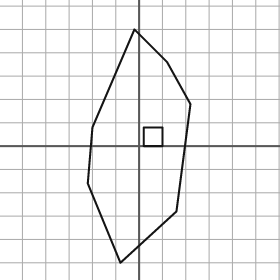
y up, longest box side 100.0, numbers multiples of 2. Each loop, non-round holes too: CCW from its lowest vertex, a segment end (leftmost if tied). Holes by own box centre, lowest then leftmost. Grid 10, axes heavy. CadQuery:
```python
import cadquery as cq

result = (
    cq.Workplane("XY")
    .moveTo(-8.0, -50.0)
    .lineTo(16.0, -28.0)
    .lineTo(22.0, 18.0)
    .lineTo(12.0, 36.0)
    .lineTo(-2.0, 50.0)
    .lineTo(-20.0, 8.0)
    .lineTo(-22.0, -16.0)
    .close()
    .moveTo(2.0, 0.0)
    .lineTo(10.0, 0.0)
    .lineTo(10.0, 8.0)
    .lineTo(2.0, 8.0)
    .close()
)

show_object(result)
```